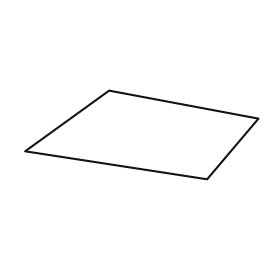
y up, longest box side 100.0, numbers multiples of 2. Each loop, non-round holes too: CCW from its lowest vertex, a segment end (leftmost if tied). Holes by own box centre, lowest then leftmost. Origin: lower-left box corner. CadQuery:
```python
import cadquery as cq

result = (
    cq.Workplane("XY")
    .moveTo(78.0, 0.0)
    .lineTo(100.0, 26.0)
    .lineTo(36.0, 38.0)
    .lineTo(0.0, 12.0)
    .close()
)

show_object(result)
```